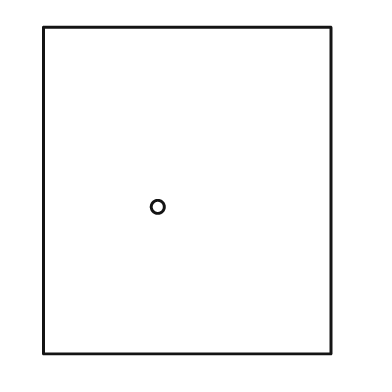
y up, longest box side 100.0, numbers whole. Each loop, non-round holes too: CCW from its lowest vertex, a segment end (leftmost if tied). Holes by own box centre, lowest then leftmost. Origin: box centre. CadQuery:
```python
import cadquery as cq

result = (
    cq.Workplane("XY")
    .moveTo(-44.0, -50.0)
    .lineTo(44.0, -50.0)
    .lineTo(44.0, 50.0)
    .lineTo(-44.0, 50.0)
    .close()
    .moveTo(-9.0, -5.0)
    .circle(2.0)
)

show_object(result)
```